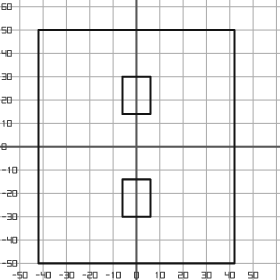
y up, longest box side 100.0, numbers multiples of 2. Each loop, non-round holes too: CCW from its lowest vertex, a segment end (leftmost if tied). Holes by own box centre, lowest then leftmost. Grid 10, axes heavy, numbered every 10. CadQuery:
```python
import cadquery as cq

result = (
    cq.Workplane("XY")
    .moveTo(-42.0, -50.0)
    .lineTo(42.0, -50.0)
    .lineTo(42.0, 50.0)
    .lineTo(-42.0, 50.0)
    .close()
    .moveTo(-6.0, -30.0)
    .lineTo(6.0, -30.0)
    .lineTo(6.0, -14.0)
    .lineTo(-6.0, -14.0)
    .close()
    .moveTo(-6.0, 14.0)
    .lineTo(6.0, 14.0)
    .lineTo(6.0, 30.0)
    .lineTo(-6.0, 30.0)
    .close()
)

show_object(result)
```